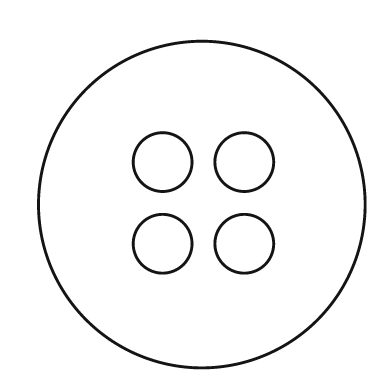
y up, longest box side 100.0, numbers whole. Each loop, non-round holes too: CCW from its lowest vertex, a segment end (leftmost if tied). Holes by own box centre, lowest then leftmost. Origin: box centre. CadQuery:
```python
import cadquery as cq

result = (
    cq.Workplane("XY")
    .moveTo(0.0, 0.0)
    .circle(50.0)
    .moveTo(-12.0, -12.0)
    .circle(9.0)
    .moveTo(13.0, -12.0)
    .circle(9.0)
    .moveTo(-12.0, 13.0)
    .circle(9.0)
    .moveTo(13.0, 13.0)
    .circle(9.0)
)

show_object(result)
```